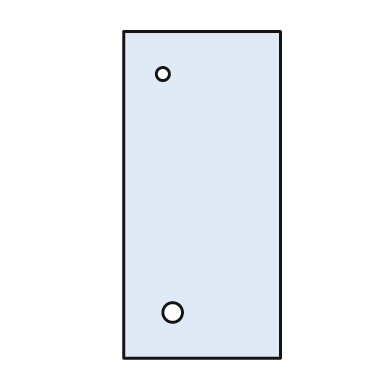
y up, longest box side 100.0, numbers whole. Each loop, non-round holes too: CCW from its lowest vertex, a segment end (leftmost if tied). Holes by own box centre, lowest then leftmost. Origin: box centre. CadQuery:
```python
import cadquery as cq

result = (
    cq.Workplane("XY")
    .moveTo(-24.0, -50.0)
    .lineTo(24.0, -50.0)
    .lineTo(24.0, 50.0)
    .lineTo(-24.0, 50.0)
    .close()
    .moveTo(-9.0, -36.0)
    .circle(3.0)
    .moveTo(-12.0, 37.0)
    .circle(2.0)
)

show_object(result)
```